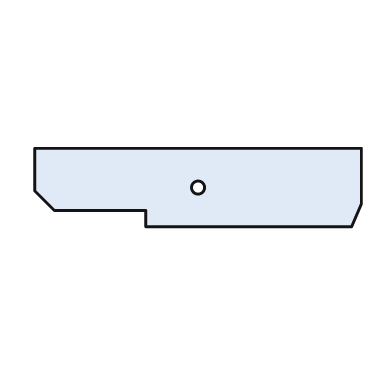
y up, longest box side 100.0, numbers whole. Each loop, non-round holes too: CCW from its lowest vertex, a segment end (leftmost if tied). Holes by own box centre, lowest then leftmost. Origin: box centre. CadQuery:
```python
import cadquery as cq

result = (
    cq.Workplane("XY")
    .moveTo(-16.0, -12.0)
    .lineTo(47.0, -12.0)
    .lineTo(50.0, -5.0)
    .lineTo(50.0, 12.0)
    .lineTo(-50.0, 12.0)
    .lineTo(-50.0, -1.0)
    .lineTo(-44.0, -7.0)
    .lineTo(-16.0, -7.0)
    .close()
    .moveTo(0.0, 0.0)
    .circle(2.0)
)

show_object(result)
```